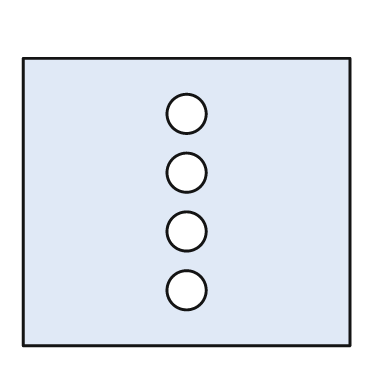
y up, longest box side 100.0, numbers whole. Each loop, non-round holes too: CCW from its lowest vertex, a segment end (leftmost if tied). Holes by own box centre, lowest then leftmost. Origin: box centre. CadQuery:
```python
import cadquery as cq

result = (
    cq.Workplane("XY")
    .moveTo(-50.0, -44.0)
    .lineTo(50.0, -44.0)
    .lineTo(50.0, 44.0)
    .lineTo(-50.0, 44.0)
    .close()
    .moveTo(0.0, -27.0)
    .circle(6.0)
    .moveTo(0.0, -9.0)
    .circle(6.0)
    .moveTo(0.0, 9.0)
    .circle(6.0)
    .moveTo(0.0, 27.0)
    .circle(6.0)
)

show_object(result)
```